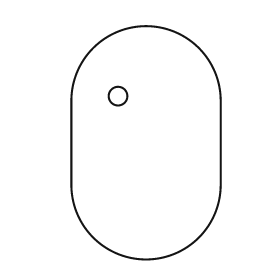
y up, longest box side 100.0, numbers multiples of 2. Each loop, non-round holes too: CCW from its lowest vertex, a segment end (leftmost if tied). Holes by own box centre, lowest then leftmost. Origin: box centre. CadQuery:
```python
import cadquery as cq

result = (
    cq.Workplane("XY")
    .moveTo(-32.0, -18.0)
    .threePointArc((0.0, -50.0), (32.0, -18.0))
    .lineTo(32.0, 18.0)
    .threePointArc((0.0, 50.0), (-32.0, 18.0))
    .close()
    .moveTo(-12.0, 20.0)
    .circle(4.0)
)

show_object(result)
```